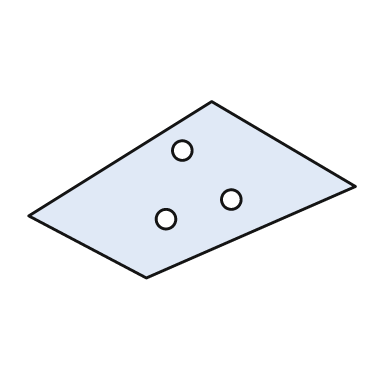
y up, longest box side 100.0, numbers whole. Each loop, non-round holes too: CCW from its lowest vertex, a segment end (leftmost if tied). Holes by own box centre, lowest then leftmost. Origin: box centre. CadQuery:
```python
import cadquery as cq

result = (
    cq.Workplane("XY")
    .moveTo(-14.0, -27.0)
    .lineTo(50.0, 1.0)
    .lineTo(6.0, 27.0)
    .lineTo(-50.0, -8.0)
    .close()
    .moveTo(-8.0, -9.0)
    .circle(3.0)
    .moveTo(12.0, -3.0)
    .circle(3.0)
    .moveTo(-3.0, 12.0)
    .circle(3.0)
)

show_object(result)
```